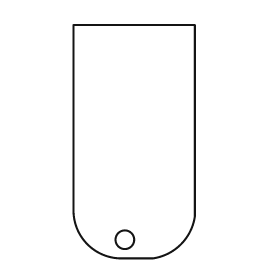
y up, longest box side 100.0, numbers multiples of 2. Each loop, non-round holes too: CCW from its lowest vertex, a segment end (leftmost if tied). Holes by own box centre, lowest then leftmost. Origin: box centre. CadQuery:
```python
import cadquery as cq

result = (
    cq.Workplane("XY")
    .moveTo(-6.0, -50.0)
    .lineTo(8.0, -50.0)
    .threePointArc((20.0, -44.0), (26.0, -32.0))
    .lineTo(26.0, 50.0)
    .lineTo(-26.0, 50.0)
    .lineTo(-26.0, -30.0)
    .threePointArc((-20.0, -44.0), (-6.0, -50.0))
    .close()
    .moveTo(-4.0, -42.0)
    .circle(4.0)
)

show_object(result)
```